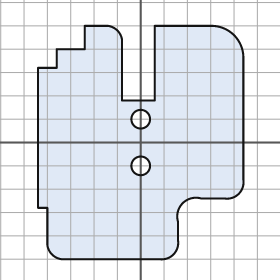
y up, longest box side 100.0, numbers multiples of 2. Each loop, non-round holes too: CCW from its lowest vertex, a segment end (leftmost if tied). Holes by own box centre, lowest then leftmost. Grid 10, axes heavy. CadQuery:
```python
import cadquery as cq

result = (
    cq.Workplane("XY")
    .moveTo(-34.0, -50.0)
    .lineTo(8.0, -50.0)
    .threePointArc((14.0, -48.0), (16.0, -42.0))
    .lineTo(16.0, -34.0)
    .threePointArc((18.0, -26.0), (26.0, -24.0))
    .lineTo(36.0, -24.0)
    .threePointArc((42.0, -22.0), (44.0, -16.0))
    .lineTo(44.0, 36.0)
    .threePointArc((40.0, 46.0), (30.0, 50.0))
    .lineTo(6.0, 50.0)
    .lineTo(6.0, 18.0)
    .lineTo(-8.0, 18.0)
    .lineTo(-8.0, 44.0)
    .threePointArc((-10.0, 48.0), (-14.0, 50.0))
    .lineTo(-24.0, 50.0)
    .lineTo(-24.0, 40.0)
    .lineTo(-36.0, 40.0)
    .lineTo(-36.0, 32.0)
    .lineTo(-44.0, 32.0)
    .lineTo(-44.0, -28.0)
    .lineTo(-40.0, -28.0)
    .lineTo(-40.0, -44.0)
    .threePointArc((-38.0, -48.0), (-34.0, -50.0))
    .close()
    .moveTo(0.0, -10.0)
    .circle(4.0)
    .moveTo(0.0, 10.0)
    .circle(4.0)
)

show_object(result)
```